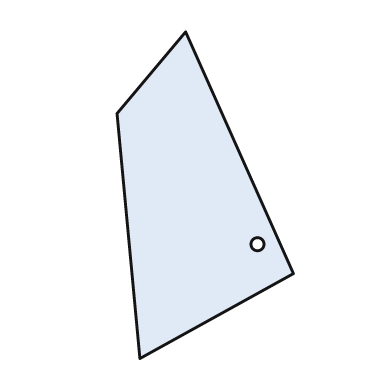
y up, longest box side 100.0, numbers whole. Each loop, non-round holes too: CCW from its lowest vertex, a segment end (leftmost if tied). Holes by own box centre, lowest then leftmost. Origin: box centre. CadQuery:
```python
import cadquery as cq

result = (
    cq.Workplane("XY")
    .moveTo(-20.0, -50.0)
    .lineTo(27.0, -24.0)
    .lineTo(-6.0, 50.0)
    .lineTo(-27.0, 25.0)
    .close()
    .moveTo(16.0, -15.0)
    .circle(2.0)
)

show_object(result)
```